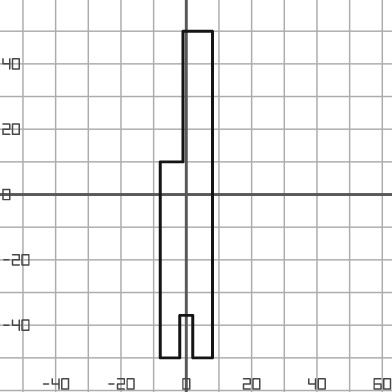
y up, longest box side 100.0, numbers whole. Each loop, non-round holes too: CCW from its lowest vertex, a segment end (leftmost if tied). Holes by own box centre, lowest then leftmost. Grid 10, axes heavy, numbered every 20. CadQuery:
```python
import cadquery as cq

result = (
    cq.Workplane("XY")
    .moveTo(-8.0, -50.0)
    .lineTo(-2.0, -50.0)
    .lineTo(-2.0, -37.0)
    .lineTo(2.0, -37.0)
    .lineTo(2.0, -50.0)
    .lineTo(8.0, -50.0)
    .lineTo(8.0, 50.0)
    .lineTo(-1.0, 50.0)
    .lineTo(-1.0, 10.0)
    .lineTo(-8.0, 10.0)
    .close()
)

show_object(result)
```